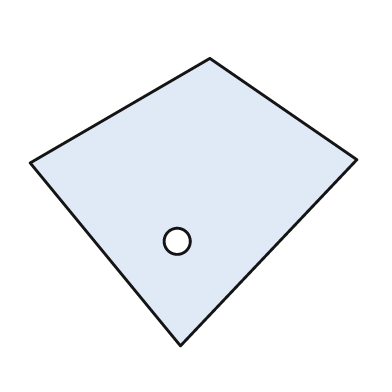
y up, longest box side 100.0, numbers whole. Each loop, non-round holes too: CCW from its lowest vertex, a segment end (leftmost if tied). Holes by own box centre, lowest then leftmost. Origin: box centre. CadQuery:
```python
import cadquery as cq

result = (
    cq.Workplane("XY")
    .moveTo(-4.0, -44.0)
    .lineTo(50.0, 13.0)
    .lineTo(5.0, 44.0)
    .lineTo(-50.0, 12.0)
    .close()
    .moveTo(-5.0, -12.0)
    .circle(4.0)
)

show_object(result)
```